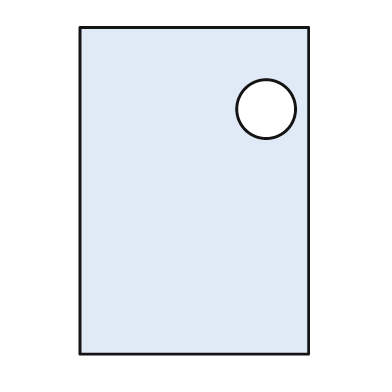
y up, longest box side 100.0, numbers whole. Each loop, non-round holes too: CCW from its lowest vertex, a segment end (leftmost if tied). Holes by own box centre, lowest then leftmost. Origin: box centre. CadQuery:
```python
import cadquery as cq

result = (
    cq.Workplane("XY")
    .moveTo(-35.0, -50.0)
    .lineTo(35.0, -50.0)
    .lineTo(35.0, 50.0)
    .lineTo(-35.0, 50.0)
    .close()
    .moveTo(22.0, 25.0)
    .circle(9.0)
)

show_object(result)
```